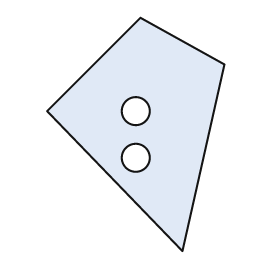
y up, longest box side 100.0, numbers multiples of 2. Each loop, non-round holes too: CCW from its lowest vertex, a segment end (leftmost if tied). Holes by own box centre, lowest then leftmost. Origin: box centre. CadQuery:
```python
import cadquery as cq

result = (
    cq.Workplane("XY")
    .moveTo(20.0, -50.0)
    .lineTo(38.0, 30.0)
    .lineTo(2.0, 50.0)
    .lineTo(-38.0, 10.0)
    .close()
    .moveTo(0.0, -10.0)
    .circle(6.0)
    .moveTo(0.0, 10.0)
    .circle(6.0)
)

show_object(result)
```